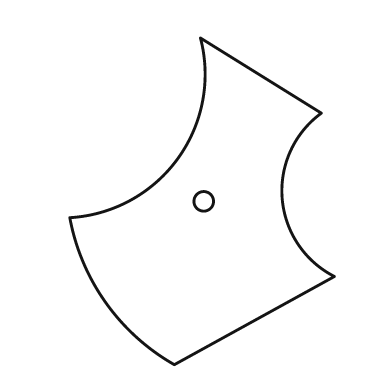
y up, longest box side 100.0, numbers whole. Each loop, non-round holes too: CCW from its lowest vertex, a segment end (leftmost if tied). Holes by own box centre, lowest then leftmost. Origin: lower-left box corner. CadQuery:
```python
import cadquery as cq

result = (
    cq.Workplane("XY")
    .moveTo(32.0, 0.0)
    .lineTo(81.0, 27.0)
    .threePointArc((65.0, 51.0), (77.0, 77.0))
    .lineTo(40.0, 100.0)
    .threePointArc((33.0, 63.0), (0.0, 45.0))
    .threePointArc((11.0, 19.0), (32.0, 0.0))
    .close()
    .moveTo(41.0, 50.0)
    .circle(3.0)
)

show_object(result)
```